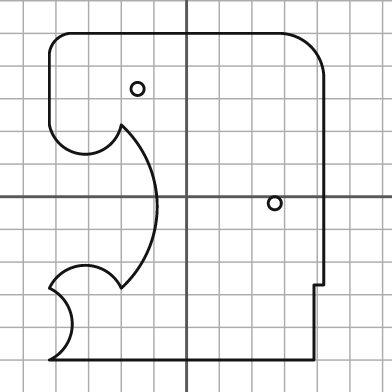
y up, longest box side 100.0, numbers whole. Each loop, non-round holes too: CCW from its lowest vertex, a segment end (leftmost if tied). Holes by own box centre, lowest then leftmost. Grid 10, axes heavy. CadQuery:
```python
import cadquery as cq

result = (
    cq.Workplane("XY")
    .moveTo(-42.0, -50.0)
    .lineTo(39.0, -50.0)
    .lineTo(39.0, -27.0)
    .lineTo(42.0, -27.0)
    .lineTo(42.0, 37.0)
    .threePointArc((38.0, 46.0), (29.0, 50.0))
    .lineTo(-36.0, 50.0)
    .threePointArc((-40.0, 48.0), (-42.0, 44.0))
    .lineTo(-42.0, 22.0)
    .threePointArc((-31.0, 13.0), (-20.0, 22.0))
    .threePointArc((-9.0, -3.0), (-20.0, -28.0))
    .threePointArc((-31.0, -21.0), (-42.0, -28.0))
    .threePointArc((-35.0, -39.0), (-42.0, -50.0))
    .close()
    .moveTo(27.0, -2.0)
    .circle(2.0)
    .moveTo(-15.0, 33.0)
    .circle(2.0)
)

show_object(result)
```